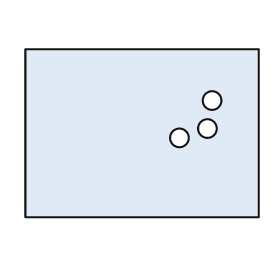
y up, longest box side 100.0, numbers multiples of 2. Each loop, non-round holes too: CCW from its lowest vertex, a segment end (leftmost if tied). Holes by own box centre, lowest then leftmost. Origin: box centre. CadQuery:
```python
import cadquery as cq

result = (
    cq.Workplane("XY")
    .moveTo(-50.0, -36.0)
    .lineTo(50.0, -36.0)
    .lineTo(50.0, 36.0)
    .lineTo(-50.0, 36.0)
    .close()
    .moveTo(16.0, -2.0)
    .circle(4.0)
    .moveTo(28.0, 2.0)
    .circle(4.0)
    .moveTo(30.0, 14.0)
    .circle(4.0)
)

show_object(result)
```